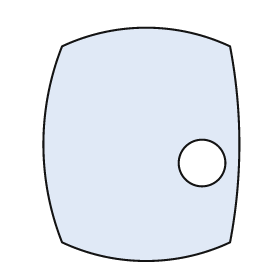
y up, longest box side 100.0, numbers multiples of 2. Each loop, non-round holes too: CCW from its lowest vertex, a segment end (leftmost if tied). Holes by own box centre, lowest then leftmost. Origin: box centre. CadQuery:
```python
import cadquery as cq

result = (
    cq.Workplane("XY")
    .moveTo(-34.0, -42.0)
    .threePointArc((2.0, -50.0), (38.0, -42.0))
    .threePointArc((42.0, 0.0), (38.0, 42.0))
    .threePointArc((2.0, 50.0), (-34.0, 42.0))
    .threePointArc((-42.0, 0.0), (-34.0, -42.0))
    .close()
    .moveTo(26.0, -8.0)
    .circle(10.0)
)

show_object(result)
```